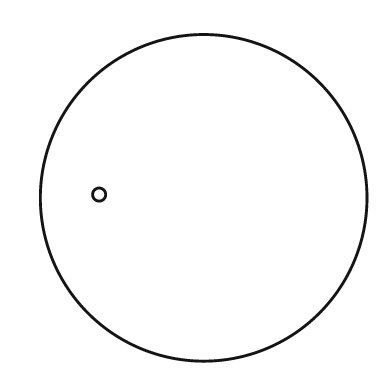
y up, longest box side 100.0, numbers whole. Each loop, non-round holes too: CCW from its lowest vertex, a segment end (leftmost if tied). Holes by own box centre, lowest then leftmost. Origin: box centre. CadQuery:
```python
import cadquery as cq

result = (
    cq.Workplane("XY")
    .moveTo(0.0, 0.0)
    .circle(50.0)
    .moveTo(-32.0, 1.0)
    .circle(2.0)
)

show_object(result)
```